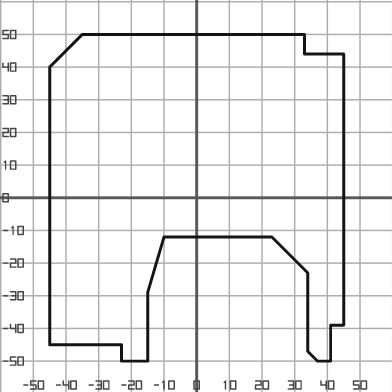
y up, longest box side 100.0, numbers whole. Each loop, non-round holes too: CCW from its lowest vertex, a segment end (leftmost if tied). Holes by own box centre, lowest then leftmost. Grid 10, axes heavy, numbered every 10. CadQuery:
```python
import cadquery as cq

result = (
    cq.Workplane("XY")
    .moveTo(-23.0, -50.0)
    .lineTo(-15.0, -50.0)
    .lineTo(-15.0, -29.0)
    .lineTo(-10.0, -12.0)
    .lineTo(23.0, -12.0)
    .lineTo(34.0, -23.0)
    .lineTo(34.0, -47.0)
    .lineTo(37.0, -50.0)
    .lineTo(41.0, -50.0)
    .lineTo(41.0, -39.0)
    .lineTo(45.0, -39.0)
    .lineTo(45.0, 44.0)
    .lineTo(33.0, 44.0)
    .lineTo(33.0, 50.0)
    .lineTo(-35.0, 50.0)
    .lineTo(-45.0, 40.0)
    .lineTo(-45.0, -45.0)
    .lineTo(-23.0, -45.0)
    .close()
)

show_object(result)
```